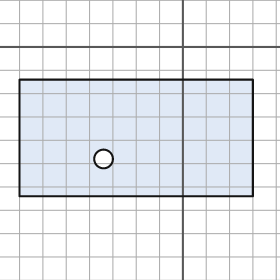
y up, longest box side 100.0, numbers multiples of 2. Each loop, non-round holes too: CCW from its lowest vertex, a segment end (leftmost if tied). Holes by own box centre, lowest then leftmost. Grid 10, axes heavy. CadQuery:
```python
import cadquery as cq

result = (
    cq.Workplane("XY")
    .moveTo(-70.0, -64.0)
    .lineTo(30.0, -64.0)
    .lineTo(30.0, -14.0)
    .lineTo(-70.0, -14.0)
    .close()
    .moveTo(-34.0, -48.0)
    .circle(4.0)
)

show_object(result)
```